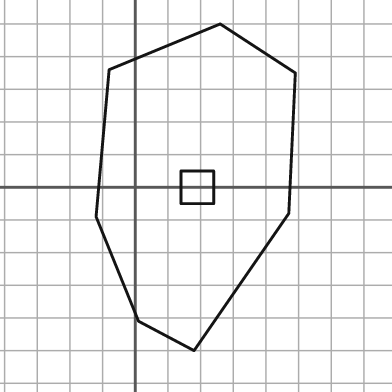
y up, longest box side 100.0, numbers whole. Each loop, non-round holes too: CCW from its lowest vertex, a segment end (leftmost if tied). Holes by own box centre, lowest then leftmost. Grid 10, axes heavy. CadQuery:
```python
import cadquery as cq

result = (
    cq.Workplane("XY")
    .moveTo(18.0, -50.0)
    .lineTo(47.0, -8.0)
    .lineTo(49.0, 35.0)
    .lineTo(26.0, 50.0)
    .lineTo(-8.0, 36.0)
    .lineTo(-12.0, -9.0)
    .lineTo(1.0, -41.0)
    .close()
    .moveTo(14.0, -5.0)
    .lineTo(24.0, -5.0)
    .lineTo(24.0, 5.0)
    .lineTo(14.0, 5.0)
    .close()
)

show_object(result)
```